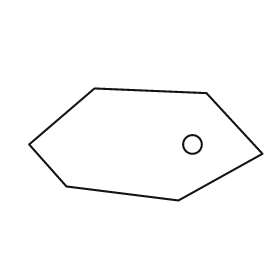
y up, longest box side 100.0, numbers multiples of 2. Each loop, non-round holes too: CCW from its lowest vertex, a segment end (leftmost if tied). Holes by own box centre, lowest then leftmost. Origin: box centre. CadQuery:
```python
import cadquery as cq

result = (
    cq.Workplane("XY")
    .moveTo(14.0, -24.0)
    .lineTo(50.0, -4.0)
    .lineTo(26.0, 22.0)
    .lineTo(-22.0, 24.0)
    .lineTo(-50.0, 0.0)
    .lineTo(-34.0, -18.0)
    .close()
    .moveTo(20.0, 0.0)
    .circle(4.0)
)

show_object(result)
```